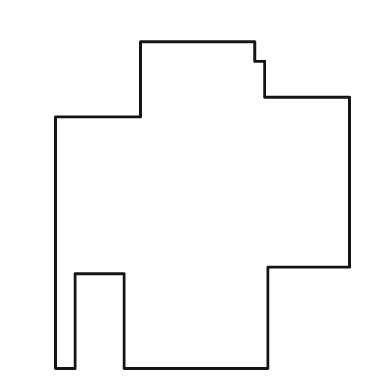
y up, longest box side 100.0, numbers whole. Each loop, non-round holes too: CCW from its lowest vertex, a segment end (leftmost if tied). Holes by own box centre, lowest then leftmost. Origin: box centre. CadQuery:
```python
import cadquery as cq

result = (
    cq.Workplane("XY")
    .moveTo(-45.0, -50.0)
    .lineTo(-39.0, -50.0)
    .lineTo(-39.0, -21.0)
    .lineTo(-24.0, -21.0)
    .lineTo(-24.0, -50.0)
    .lineTo(20.0, -50.0)
    .lineTo(20.0, -19.0)
    .lineTo(45.0, -19.0)
    .lineTo(45.0, 33.0)
    .lineTo(19.0, 33.0)
    .lineTo(19.0, 44.0)
    .lineTo(16.0, 44.0)
    .lineTo(16.0, 50.0)
    .lineTo(-19.0, 50.0)
    .lineTo(-19.0, 27.0)
    .lineTo(-45.0, 27.0)
    .close()
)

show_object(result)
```